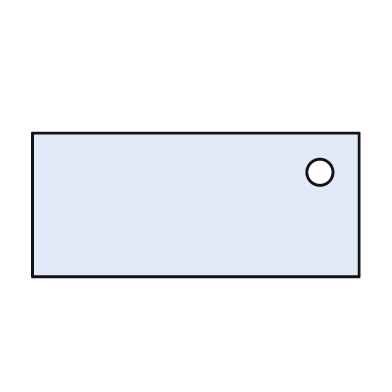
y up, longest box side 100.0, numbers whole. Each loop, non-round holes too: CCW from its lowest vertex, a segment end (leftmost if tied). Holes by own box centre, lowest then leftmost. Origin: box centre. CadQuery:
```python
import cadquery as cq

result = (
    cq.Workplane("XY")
    .moveTo(-50.0, -22.0)
    .lineTo(50.0, -22.0)
    .lineTo(50.0, 22.0)
    .lineTo(-50.0, 22.0)
    .close()
    .moveTo(38.0, 10.0)
    .circle(4.0)
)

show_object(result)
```